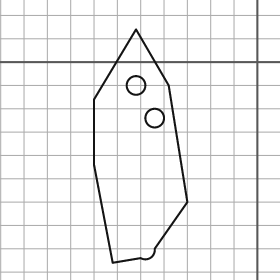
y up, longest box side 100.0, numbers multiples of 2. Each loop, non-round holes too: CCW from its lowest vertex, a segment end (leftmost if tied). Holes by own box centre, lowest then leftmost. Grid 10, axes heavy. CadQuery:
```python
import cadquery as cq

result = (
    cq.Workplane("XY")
    .moveTo(-62.0, -86.0)
    .lineTo(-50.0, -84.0)
    .threePointArc((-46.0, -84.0), (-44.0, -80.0))
    .lineTo(-30.0, -60.0)
    .lineTo(-38.0, -10.0)
    .lineTo(-52.0, 14.0)
    .lineTo(-70.0, -16.0)
    .lineTo(-70.0, -44.0)
    .close()
    .moveTo(-44.0, -24.0)
    .circle(4.0)
    .moveTo(-52.0, -10.0)
    .circle(4.0)
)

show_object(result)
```